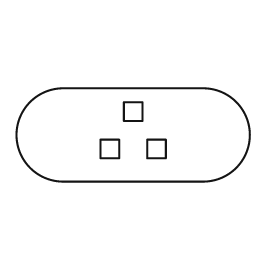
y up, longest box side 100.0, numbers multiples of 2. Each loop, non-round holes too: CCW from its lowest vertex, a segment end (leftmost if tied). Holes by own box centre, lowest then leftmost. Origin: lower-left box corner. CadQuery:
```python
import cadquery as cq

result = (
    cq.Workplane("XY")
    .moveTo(20.0, 0.0)
    .lineTo(80.0, 0.0)
    .threePointArc((100.0, 20.0), (80.0, 40.0))
    .lineTo(20.0, 40.0)
    .threePointArc((0.0, 20.0), (20.0, 0.0))
    .close()
    .moveTo(36.0, 10.0)
    .lineTo(44.0, 10.0)
    .lineTo(44.0, 18.0)
    .lineTo(36.0, 18.0)
    .close()
    .moveTo(56.0, 10.0)
    .lineTo(64.0, 10.0)
    .lineTo(64.0, 18.0)
    .lineTo(56.0, 18.0)
    .close()
    .moveTo(46.0, 26.0)
    .lineTo(54.0, 26.0)
    .lineTo(54.0, 34.0)
    .lineTo(46.0, 34.0)
    .close()
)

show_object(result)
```